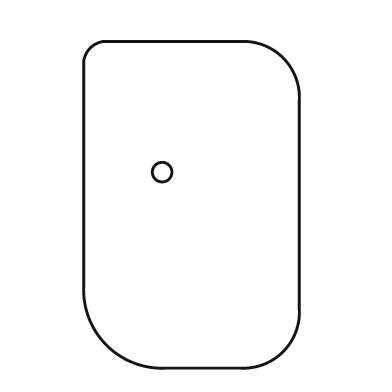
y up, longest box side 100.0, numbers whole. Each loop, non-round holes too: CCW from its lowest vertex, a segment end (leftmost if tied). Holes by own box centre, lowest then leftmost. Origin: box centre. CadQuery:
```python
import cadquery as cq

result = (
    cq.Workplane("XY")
    .moveTo(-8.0, -50.0)
    .lineTo(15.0, -50.0)
    .threePointArc((28.0, -45.0), (33.0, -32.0))
    .lineTo(33.0, 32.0)
    .threePointArc((28.0, 45.0), (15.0, 50.0))
    .lineTo(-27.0, 50.0)
    .threePointArc((-31.0, 48.0), (-33.0, 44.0))
    .lineTo(-33.0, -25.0)
    .threePointArc((-26.0, -43.0), (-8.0, -50.0))
    .close()
    .moveTo(-9.0, 10.0)
    .circle(3.0)
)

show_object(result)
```